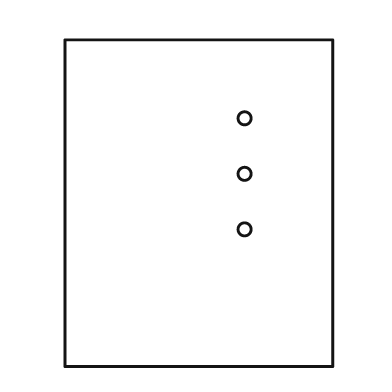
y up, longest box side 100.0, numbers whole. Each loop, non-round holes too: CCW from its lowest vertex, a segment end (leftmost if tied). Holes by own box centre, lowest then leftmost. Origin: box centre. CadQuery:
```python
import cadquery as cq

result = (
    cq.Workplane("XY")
    .moveTo(-41.0, -50.0)
    .lineTo(41.0, -50.0)
    .lineTo(41.0, 50.0)
    .lineTo(-41.0, 50.0)
    .close()
    .moveTo(14.0, -8.0)
    .circle(2.0)
    .moveTo(14.0, 9.0)
    .circle(2.0)
    .moveTo(14.0, 26.0)
    .circle(2.0)
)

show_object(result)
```